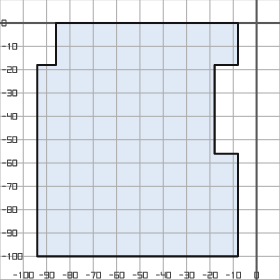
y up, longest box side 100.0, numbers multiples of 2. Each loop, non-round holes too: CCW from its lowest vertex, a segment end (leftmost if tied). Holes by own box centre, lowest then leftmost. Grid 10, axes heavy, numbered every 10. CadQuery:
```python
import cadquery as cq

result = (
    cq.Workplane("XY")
    .moveTo(-94.0, -100.0)
    .lineTo(-8.0, -100.0)
    .lineTo(-8.0, -56.0)
    .lineTo(-18.0, -56.0)
    .lineTo(-18.0, -18.0)
    .lineTo(-8.0, -18.0)
    .lineTo(-8.0, 0.0)
    .lineTo(-86.0, 0.0)
    .lineTo(-86.0, -18.0)
    .lineTo(-94.0, -18.0)
    .close()
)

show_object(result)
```